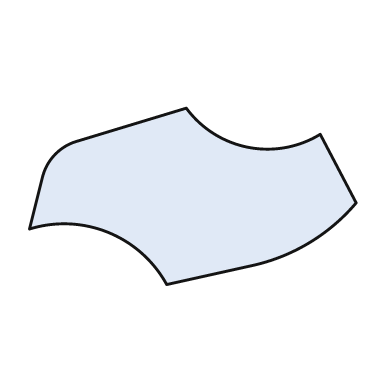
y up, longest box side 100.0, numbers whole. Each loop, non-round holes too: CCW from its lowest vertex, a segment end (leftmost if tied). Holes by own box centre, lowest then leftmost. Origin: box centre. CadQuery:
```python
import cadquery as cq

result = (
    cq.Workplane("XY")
    .moveTo(-8.0, -27.0)
    .lineTo(19.0, -21.0)
    .threePointArc((36.0, -14.0), (50.0, -2.0))
    .lineTo(39.0, 19.0)
    .threePointArc((17.0, 15.0), (-2.0, 27.0))
    .lineTo(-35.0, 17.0)
    .threePointArc((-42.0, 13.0), (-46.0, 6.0))
    .lineTo(-50.0, -10.0)
    .threePointArc((-26.0, -11.0), (-8.0, -27.0))
    .close()
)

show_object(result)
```